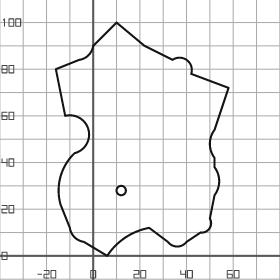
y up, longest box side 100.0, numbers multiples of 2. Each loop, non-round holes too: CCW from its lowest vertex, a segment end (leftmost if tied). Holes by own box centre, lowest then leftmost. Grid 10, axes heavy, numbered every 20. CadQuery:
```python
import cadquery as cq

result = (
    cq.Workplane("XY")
    .moveTo(6.0, 0.0)
    .threePointArc((14.0, 8.0), (24.0, 12.0))
    .lineTo(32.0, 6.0)
    .threePointArc((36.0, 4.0), (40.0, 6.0))
    .lineTo(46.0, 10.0)
    .threePointArc((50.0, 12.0), (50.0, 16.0))
    .lineTo(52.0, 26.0)
    .threePointArc((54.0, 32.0), (52.0, 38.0))
    .lineTo(52.0, 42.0)
    .threePointArc((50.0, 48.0), (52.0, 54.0))
    .lineTo(58.0, 72.0)
    .lineTo(42.0, 78.0)
    .threePointArc((40.0, 84.0), (34.0, 84.0))
    .lineTo(22.0, 90.0)
    .lineTo(10.0, 100.0)
    .lineTo(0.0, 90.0)
    .threePointArc((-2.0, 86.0), (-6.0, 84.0))
    .lineTo(-16.0, 80.0)
    .lineTo(-12.0, 60.0)
    .threePointArc((-2.0, 54.0), (-8.0, 44.0))
    .threePointArc((-14.0, 34.0), (-14.0, 22.0))
    .lineTo(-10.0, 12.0)
    .threePointArc((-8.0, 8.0), (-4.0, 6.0))
    .close()
    .moveTo(12.0, 28.0)
    .circle(2.0)
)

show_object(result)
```